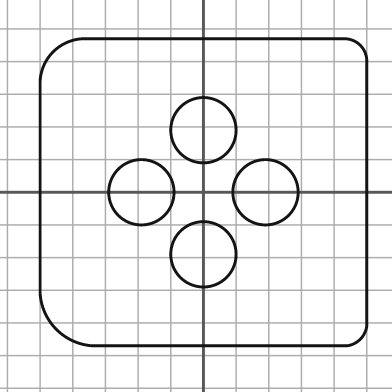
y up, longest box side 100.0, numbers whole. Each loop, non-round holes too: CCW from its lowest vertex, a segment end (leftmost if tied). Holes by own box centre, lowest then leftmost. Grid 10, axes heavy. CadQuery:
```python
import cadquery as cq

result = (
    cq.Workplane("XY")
    .moveTo(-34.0, -47.0)
    .lineTo(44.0, -47.0)
    .threePointArc((48.0, -45.0), (50.0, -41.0))
    .lineTo(50.0, 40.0)
    .threePointArc((48.0, 45.0), (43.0, 47.0))
    .lineTo(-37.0, 47.0)
    .threePointArc((-46.0, 43.0), (-50.0, 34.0))
    .lineTo(-50.0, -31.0)
    .threePointArc((-45.0, -42.0), (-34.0, -47.0))
    .close()
    .moveTo(0.0, -19.0)
    .circle(10.0)
    .moveTo(-19.0, 0.0)
    .circle(10.0)
    .moveTo(19.0, 0.0)
    .circle(10.0)
    .moveTo(0.0, 19.0)
    .circle(10.0)
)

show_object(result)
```